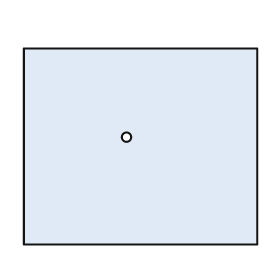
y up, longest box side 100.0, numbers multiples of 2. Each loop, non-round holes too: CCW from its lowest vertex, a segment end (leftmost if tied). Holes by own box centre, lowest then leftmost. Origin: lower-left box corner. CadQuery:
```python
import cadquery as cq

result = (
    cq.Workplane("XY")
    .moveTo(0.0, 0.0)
    .lineTo(100.0, 0.0)
    .lineTo(100.0, 84.0)
    .lineTo(0.0, 84.0)
    .close()
    .moveTo(44.0, 46.0)
    .circle(2.0)
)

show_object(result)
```